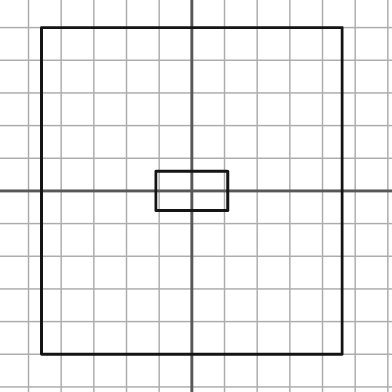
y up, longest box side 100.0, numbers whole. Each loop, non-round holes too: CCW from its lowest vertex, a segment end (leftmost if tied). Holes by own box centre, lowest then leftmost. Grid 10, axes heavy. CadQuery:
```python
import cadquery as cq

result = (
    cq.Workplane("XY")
    .moveTo(-46.0, -50.0)
    .lineTo(46.0, -50.0)
    .lineTo(46.0, 50.0)
    .lineTo(-46.0, 50.0)
    .close()
    .moveTo(-11.0, -6.0)
    .lineTo(11.0, -6.0)
    .lineTo(11.0, 6.0)
    .lineTo(-11.0, 6.0)
    .close()
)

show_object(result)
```